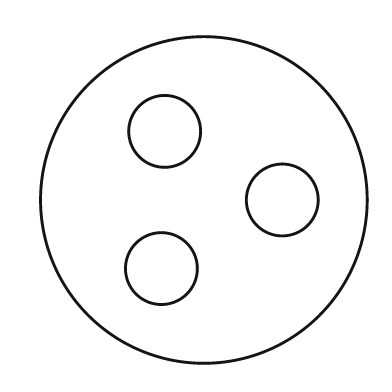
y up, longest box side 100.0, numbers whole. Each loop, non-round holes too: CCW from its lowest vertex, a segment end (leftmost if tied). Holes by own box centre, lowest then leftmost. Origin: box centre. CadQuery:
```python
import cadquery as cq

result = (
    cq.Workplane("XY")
    .moveTo(0.0, 0.0)
    .circle(50.0)
    .moveTo(-13.0, -21.0)
    .circle(11.0)
    .moveTo(24.0, 0.0)
    .circle(11.0)
    .moveTo(-12.0, 21.0)
    .circle(11.0)
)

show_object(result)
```